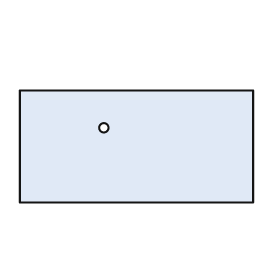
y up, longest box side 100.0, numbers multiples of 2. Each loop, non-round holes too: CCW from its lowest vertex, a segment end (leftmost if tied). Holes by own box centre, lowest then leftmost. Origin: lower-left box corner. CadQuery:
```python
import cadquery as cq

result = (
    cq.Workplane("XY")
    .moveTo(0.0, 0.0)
    .lineTo(100.0, 0.0)
    .lineTo(100.0, 48.0)
    .lineTo(0.0, 48.0)
    .close()
    .moveTo(36.0, 32.0)
    .circle(2.0)
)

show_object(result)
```